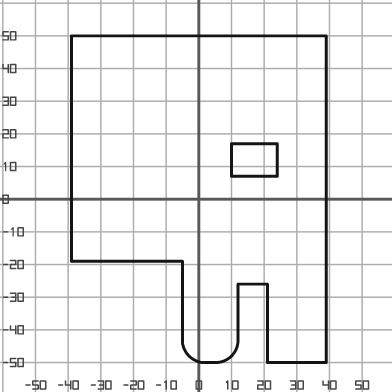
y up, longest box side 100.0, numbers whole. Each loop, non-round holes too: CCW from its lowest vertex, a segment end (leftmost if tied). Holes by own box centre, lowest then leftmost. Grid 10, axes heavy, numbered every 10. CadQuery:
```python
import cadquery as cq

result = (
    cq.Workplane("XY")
    .moveTo(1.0, -50.0)
    .lineTo(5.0, -50.0)
    .threePointArc((10.0, -48.0), (12.0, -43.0))
    .lineTo(12.0, -26.0)
    .lineTo(21.0, -26.0)
    .lineTo(21.0, -50.0)
    .lineTo(39.0, -50.0)
    .lineTo(39.0, 50.0)
    .lineTo(-39.0, 50.0)
    .lineTo(-39.0, -19.0)
    .lineTo(-5.0, -19.0)
    .lineTo(-5.0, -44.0)
    .threePointArc((-3.0, -48.0), (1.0, -50.0))
    .close()
    .moveTo(10.0, 7.0)
    .lineTo(24.0, 7.0)
    .lineTo(24.0, 17.0)
    .lineTo(10.0, 17.0)
    .close()
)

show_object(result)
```